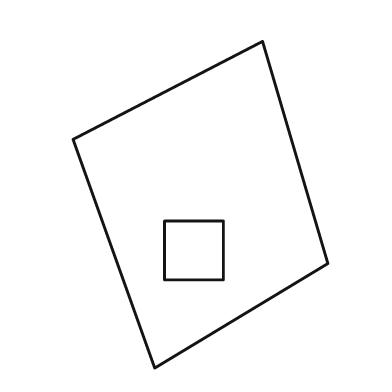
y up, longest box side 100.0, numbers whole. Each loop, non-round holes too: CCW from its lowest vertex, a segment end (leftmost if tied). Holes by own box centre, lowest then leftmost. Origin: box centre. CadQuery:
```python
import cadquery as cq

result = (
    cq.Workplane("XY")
    .moveTo(-14.0, -50.0)
    .lineTo(39.0, -18.0)
    .lineTo(19.0, 50.0)
    .lineTo(-39.0, 20.0)
    .close()
    .moveTo(-11.0, -23.0)
    .lineTo(7.0, -23.0)
    .lineTo(7.0, -5.0)
    .lineTo(-11.0, -5.0)
    .close()
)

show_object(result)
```